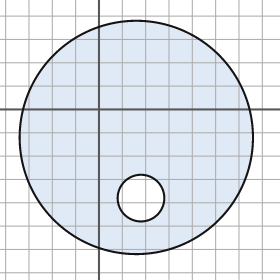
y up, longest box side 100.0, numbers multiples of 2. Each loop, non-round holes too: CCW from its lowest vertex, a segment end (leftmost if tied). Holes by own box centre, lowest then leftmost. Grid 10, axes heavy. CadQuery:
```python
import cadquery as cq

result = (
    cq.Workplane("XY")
    .moveTo(16.0, -12.0)
    .circle(50.0)
    .moveTo(18.0, -38.0)
    .circle(10.0)
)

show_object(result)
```